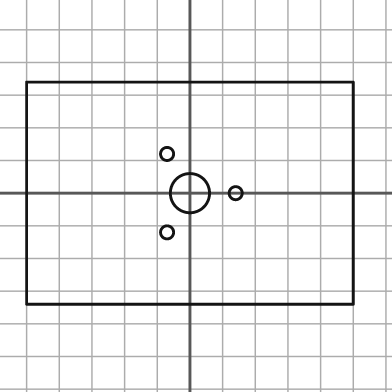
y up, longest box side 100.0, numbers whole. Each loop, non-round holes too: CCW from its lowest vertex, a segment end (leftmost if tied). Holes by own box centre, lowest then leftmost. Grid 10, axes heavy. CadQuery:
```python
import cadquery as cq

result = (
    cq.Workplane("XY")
    .moveTo(-50.0, -34.0)
    .lineTo(50.0, -34.0)
    .lineTo(50.0, 34.0)
    .lineTo(-50.0, 34.0)
    .close()
    .moveTo(-7.0, -12.0)
    .circle(2.0)
    .moveTo(0.0, 0.0)
    .circle(6.0)
    .moveTo(14.0, 0.0)
    .circle(2.0)
    .moveTo(-7.0, 12.0)
    .circle(2.0)
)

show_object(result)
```